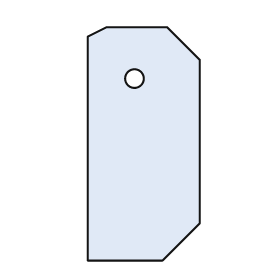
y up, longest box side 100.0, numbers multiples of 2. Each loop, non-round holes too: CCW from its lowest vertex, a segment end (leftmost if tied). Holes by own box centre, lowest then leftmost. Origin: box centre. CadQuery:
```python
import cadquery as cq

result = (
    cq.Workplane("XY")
    .moveTo(-24.0, -50.0)
    .lineTo(8.0, -50.0)
    .lineTo(24.0, -34.0)
    .lineTo(24.0, 36.0)
    .lineTo(10.0, 50.0)
    .lineTo(-16.0, 50.0)
    .lineTo(-24.0, 46.0)
    .close()
    .moveTo(-4.0, 28.0)
    .circle(4.0)
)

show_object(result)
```